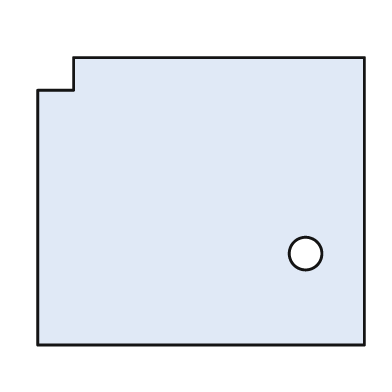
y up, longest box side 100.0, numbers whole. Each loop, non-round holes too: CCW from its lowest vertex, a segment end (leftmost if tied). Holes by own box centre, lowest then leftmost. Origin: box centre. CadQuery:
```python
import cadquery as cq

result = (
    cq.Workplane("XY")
    .moveTo(-50.0, -44.0)
    .lineTo(50.0, -44.0)
    .lineTo(50.0, 44.0)
    .lineTo(-39.0, 44.0)
    .lineTo(-39.0, 34.0)
    .lineTo(-50.0, 34.0)
    .close()
    .moveTo(32.0, -16.0)
    .circle(5.0)
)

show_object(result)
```